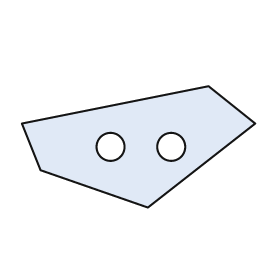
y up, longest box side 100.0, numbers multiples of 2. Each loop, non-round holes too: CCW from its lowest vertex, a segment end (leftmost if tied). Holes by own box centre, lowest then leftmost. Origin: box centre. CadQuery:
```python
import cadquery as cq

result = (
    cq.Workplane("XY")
    .moveTo(4.0, -26.0)
    .lineTo(50.0, 10.0)
    .lineTo(30.0, 26.0)
    .lineTo(-50.0, 10.0)
    .lineTo(-42.0, -10.0)
    .close()
    .moveTo(-12.0, 0.0)
    .circle(6.0)
    .moveTo(14.0, 0.0)
    .circle(6.0)
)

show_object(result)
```